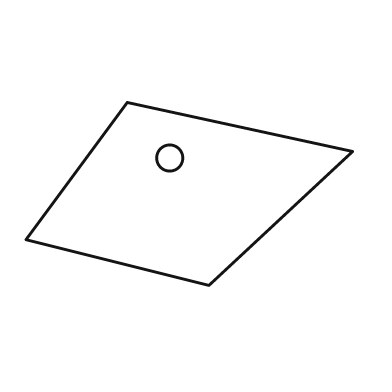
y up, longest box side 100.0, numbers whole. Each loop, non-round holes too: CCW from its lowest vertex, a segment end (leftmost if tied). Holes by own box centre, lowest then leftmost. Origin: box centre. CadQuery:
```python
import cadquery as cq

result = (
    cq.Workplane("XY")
    .moveTo(6.0, -28.0)
    .lineTo(50.0, 13.0)
    .lineTo(-19.0, 28.0)
    .lineTo(-50.0, -14.0)
    .close()
    .moveTo(-6.0, 11.0)
    .circle(4.0)
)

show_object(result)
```